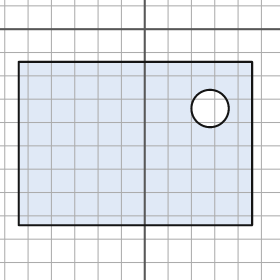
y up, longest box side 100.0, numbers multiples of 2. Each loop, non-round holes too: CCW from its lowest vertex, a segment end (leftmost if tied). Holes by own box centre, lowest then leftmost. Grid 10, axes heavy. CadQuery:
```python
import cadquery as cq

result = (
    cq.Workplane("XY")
    .moveTo(-54.0, -84.0)
    .lineTo(46.0, -84.0)
    .lineTo(46.0, -14.0)
    .lineTo(-54.0, -14.0)
    .close()
    .moveTo(28.0, -34.0)
    .circle(8.0)
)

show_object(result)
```